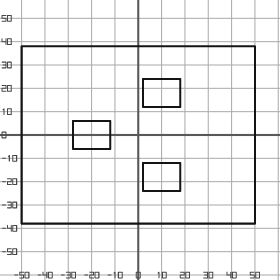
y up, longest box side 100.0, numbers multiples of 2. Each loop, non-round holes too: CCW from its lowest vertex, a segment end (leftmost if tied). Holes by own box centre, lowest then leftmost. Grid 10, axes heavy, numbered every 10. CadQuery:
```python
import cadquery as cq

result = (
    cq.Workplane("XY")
    .moveTo(-50.0, -38.0)
    .lineTo(50.0, -38.0)
    .lineTo(50.0, 38.0)
    .lineTo(-50.0, 38.0)
    .close()
    .moveTo(2.0, -24.0)
    .lineTo(18.0, -24.0)
    .lineTo(18.0, -12.0)
    .lineTo(2.0, -12.0)
    .close()
    .moveTo(-28.0, -6.0)
    .lineTo(-12.0, -6.0)
    .lineTo(-12.0, 6.0)
    .lineTo(-28.0, 6.0)
    .close()
    .moveTo(2.0, 12.0)
    .lineTo(18.0, 12.0)
    .lineTo(18.0, 24.0)
    .lineTo(2.0, 24.0)
    .close()
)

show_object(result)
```